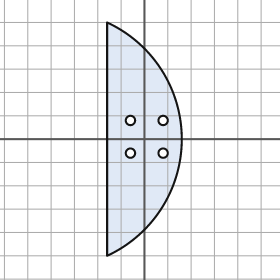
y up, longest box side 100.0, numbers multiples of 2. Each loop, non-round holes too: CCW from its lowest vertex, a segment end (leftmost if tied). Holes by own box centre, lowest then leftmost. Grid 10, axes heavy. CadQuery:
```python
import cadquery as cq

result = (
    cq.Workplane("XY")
    .moveTo(-16.0, -50.0)
    .threePointArc((16.0, 0.0), (-16.0, 50.0))
    .close()
    .moveTo(-6.0, -6.0)
    .circle(2.0)
    .moveTo(8.0, -6.0)
    .circle(2.0)
    .moveTo(-6.0, 8.0)
    .circle(2.0)
    .moveTo(8.0, 8.0)
    .circle(2.0)
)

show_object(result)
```